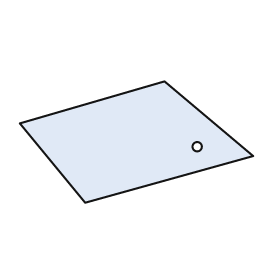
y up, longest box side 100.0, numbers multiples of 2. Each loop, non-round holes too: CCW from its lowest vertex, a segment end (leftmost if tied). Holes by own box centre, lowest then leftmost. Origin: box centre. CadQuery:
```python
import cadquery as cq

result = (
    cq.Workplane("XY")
    .moveTo(-22.0, -26.0)
    .lineTo(50.0, -6.0)
    .lineTo(12.0, 26.0)
    .lineTo(-50.0, 8.0)
    .close()
    .moveTo(26.0, -2.0)
    .circle(2.0)
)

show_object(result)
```